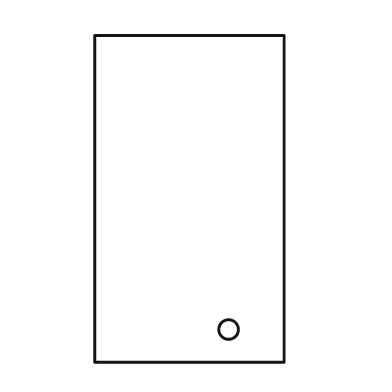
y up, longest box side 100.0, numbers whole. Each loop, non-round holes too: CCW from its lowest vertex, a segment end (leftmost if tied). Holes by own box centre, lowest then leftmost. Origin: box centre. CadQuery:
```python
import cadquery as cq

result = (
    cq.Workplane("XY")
    .moveTo(-29.0, -50.0)
    .lineTo(29.0, -50.0)
    .lineTo(29.0, 50.0)
    .lineTo(-29.0, 50.0)
    .close()
    .moveTo(12.0, -40.0)
    .circle(3.0)
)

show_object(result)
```